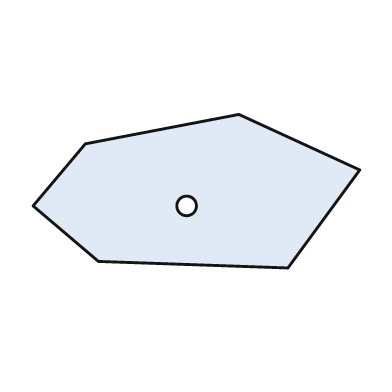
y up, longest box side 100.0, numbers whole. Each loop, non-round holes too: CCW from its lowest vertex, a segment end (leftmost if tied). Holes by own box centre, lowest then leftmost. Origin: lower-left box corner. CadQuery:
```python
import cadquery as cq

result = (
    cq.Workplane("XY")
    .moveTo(78.0, 0.0)
    .lineTo(100.0, 30.0)
    .lineTo(63.0, 47.0)
    .lineTo(16.0, 38.0)
    .lineTo(0.0, 19.0)
    .lineTo(20.0, 2.0)
    .close()
    .moveTo(47.0, 19.0)
    .circle(3.0)
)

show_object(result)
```